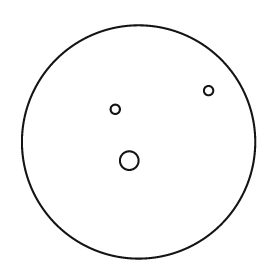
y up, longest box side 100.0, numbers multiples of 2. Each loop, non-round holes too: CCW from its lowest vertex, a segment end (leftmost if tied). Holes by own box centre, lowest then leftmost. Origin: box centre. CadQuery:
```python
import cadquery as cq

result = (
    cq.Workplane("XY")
    .moveTo(0.0, 0.0)
    .circle(50.0)
    .moveTo(-4.0, -8.0)
    .circle(4.0)
    .moveTo(-10.0, 14.0)
    .circle(2.0)
    .moveTo(30.0, 22.0)
    .circle(2.0)
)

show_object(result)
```